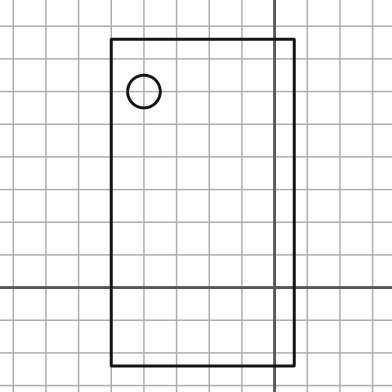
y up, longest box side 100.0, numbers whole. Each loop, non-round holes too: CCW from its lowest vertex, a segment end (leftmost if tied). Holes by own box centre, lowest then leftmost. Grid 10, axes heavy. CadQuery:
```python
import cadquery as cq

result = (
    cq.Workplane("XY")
    .moveTo(-50.0, -24.0)
    .lineTo(6.0, -24.0)
    .lineTo(6.0, 76.0)
    .lineTo(-50.0, 76.0)
    .close()
    .moveTo(-40.0, 60.0)
    .circle(5.0)
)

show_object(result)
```